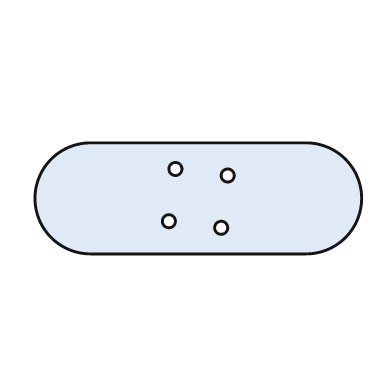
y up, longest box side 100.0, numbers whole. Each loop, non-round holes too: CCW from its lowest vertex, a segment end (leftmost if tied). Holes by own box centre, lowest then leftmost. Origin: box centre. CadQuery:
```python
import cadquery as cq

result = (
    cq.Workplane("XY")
    .moveTo(-33.0, -17.0)
    .lineTo(33.0, -17.0)
    .threePointArc((50.0, 0.0), (33.0, 17.0))
    .lineTo(-33.0, 17.0)
    .threePointArc((-50.0, 0.0), (-33.0, -17.0))
    .close()
    .moveTo(7.0, -9.0)
    .circle(2.0)
    .moveTo(-9.0, -7.0)
    .circle(2.0)
    .moveTo(9.0, 7.0)
    .circle(2.0)
    .moveTo(-7.0, 9.0)
    .circle(2.0)
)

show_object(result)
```